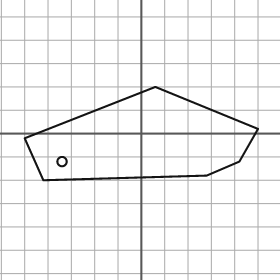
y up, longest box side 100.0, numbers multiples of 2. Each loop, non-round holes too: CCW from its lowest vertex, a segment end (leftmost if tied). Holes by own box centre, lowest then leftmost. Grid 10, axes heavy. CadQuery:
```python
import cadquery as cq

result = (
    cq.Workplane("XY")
    .moveTo(-42.0, -20.0)
    .lineTo(28.0, -18.0)
    .lineTo(42.0, -12.0)
    .lineTo(50.0, 2.0)
    .lineTo(6.0, 20.0)
    .lineTo(-50.0, -2.0)
    .close()
    .moveTo(-34.0, -12.0)
    .circle(2.0)
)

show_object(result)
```